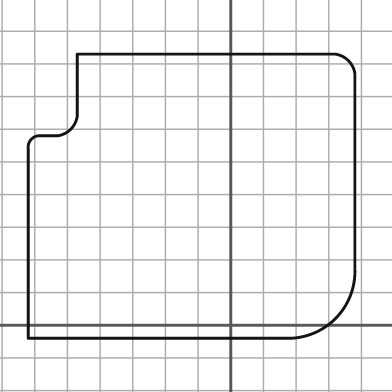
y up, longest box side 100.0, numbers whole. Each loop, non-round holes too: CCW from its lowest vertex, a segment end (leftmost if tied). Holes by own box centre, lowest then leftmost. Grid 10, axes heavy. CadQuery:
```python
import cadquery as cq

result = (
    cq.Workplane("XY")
    .moveTo(-62.0, -4.0)
    .lineTo(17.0, -4.0)
    .threePointArc((32.0, 2.0), (38.0, 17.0))
    .lineTo(38.0, 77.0)
    .threePointArc((36.0, 81.0), (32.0, 83.0))
    .lineTo(-47.0, 83.0)
    .lineTo(-47.0, 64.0)
    .threePointArc((-49.0, 60.0), (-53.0, 58.0))
    .lineTo(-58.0, 58.0)
    .threePointArc((-61.0, 57.0), (-62.0, 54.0))
    .close()
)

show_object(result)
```